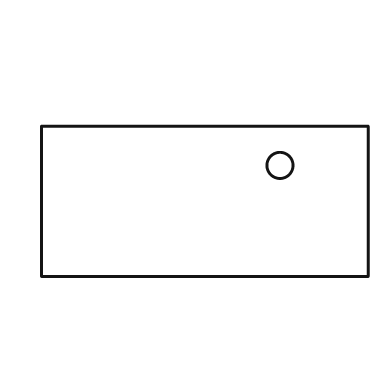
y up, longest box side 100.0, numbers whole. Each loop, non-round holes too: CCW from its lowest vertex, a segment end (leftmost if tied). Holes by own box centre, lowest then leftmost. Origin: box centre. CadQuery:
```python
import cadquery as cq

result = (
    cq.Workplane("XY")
    .moveTo(-50.0, -23.0)
    .lineTo(50.0, -23.0)
    .lineTo(50.0, 23.0)
    .lineTo(-50.0, 23.0)
    .close()
    .moveTo(23.0, 11.0)
    .circle(4.0)
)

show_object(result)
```